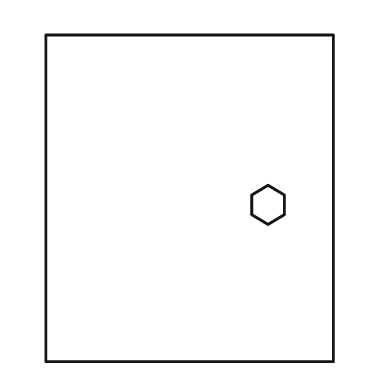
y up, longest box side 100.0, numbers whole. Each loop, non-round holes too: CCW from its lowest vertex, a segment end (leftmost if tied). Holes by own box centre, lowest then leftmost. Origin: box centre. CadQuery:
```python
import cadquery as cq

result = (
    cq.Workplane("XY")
    .moveTo(-44.0, -50.0)
    .lineTo(44.0, -50.0)
    .lineTo(44.0, 50.0)
    .lineTo(-44.0, 50.0)
    .close()
    .moveTo(24.0, -8.0)
    .lineTo(29.0, -5.0)
    .lineTo(29.0, 1.0)
    .lineTo(24.0, 4.0)
    .lineTo(19.0, 1.0)
    .lineTo(19.0, -5.0)
    .close()
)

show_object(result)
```